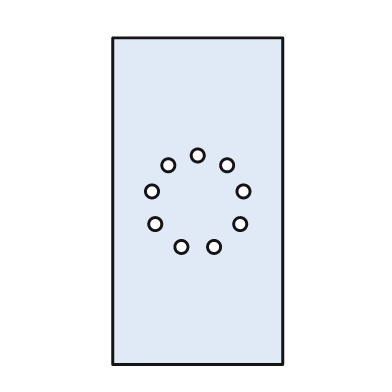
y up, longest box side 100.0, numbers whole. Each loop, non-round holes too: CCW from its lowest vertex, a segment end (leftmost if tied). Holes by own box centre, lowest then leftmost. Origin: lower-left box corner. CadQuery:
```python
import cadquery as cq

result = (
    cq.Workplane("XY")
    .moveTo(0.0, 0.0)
    .lineTo(52.0, 0.0)
    .lineTo(52.0, 100.0)
    .lineTo(0.0, 100.0)
    .close()
    .moveTo(21.0, 36.0)
    .circle(2.0)
    .moveTo(31.0, 36.0)
    .circle(2.0)
    .moveTo(13.0, 43.0)
    .circle(2.0)
    .moveTo(39.0, 43.0)
    .circle(2.0)
    .moveTo(12.0, 53.0)
    .circle(2.0)
    .moveTo(40.0, 53.0)
    .circle(2.0)
    .moveTo(17.0, 61.0)
    .circle(2.0)
    .moveTo(35.0, 61.0)
    .circle(2.0)
    .moveTo(26.0, 64.0)
    .circle(2.0)
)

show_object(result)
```